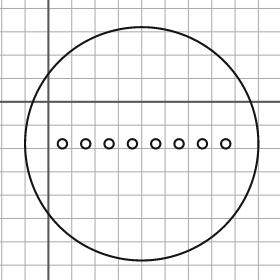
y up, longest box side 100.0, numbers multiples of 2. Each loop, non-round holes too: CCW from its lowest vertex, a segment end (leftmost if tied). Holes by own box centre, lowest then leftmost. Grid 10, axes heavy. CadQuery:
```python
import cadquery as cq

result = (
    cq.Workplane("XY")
    .moveTo(40.0, -18.0)
    .circle(50.0)
    .moveTo(6.0, -18.0)
    .circle(2.0)
    .moveTo(16.0, -18.0)
    .circle(2.0)
    .moveTo(26.0, -18.0)
    .circle(2.0)
    .moveTo(36.0, -18.0)
    .circle(2.0)
    .moveTo(46.0, -18.0)
    .circle(2.0)
    .moveTo(56.0, -18.0)
    .circle(2.0)
    .moveTo(66.0, -18.0)
    .circle(2.0)
    .moveTo(76.0, -18.0)
    .circle(2.0)
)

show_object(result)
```